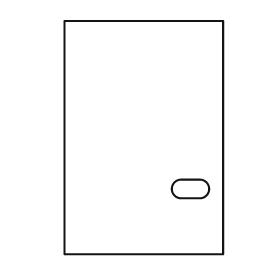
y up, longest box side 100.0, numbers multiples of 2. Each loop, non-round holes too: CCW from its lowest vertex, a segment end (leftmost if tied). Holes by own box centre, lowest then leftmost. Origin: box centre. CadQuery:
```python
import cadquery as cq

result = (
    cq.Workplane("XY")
    .moveTo(-34.0, -50.0)
    .lineTo(34.0, -50.0)
    .lineTo(34.0, 50.0)
    .lineTo(-34.0, 50.0)
    .close()
    .moveTo(16.0, -26.0)
    .lineTo(24.0, -26.0)
    .threePointArc((28.0, -22.0), (24.0, -18.0))
    .lineTo(16.0, -18.0)
    .threePointArc((12.0, -22.0), (16.0, -26.0))
    .close()
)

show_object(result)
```